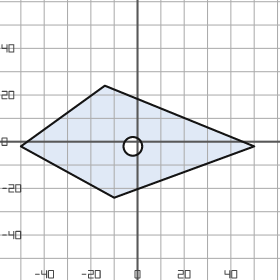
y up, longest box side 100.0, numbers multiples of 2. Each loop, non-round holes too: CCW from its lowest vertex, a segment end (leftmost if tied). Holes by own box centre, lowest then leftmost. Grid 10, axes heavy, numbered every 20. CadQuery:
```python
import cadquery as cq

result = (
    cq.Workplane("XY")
    .moveTo(-10.0, -24.0)
    .lineTo(50.0, -2.0)
    .lineTo(-14.0, 24.0)
    .lineTo(-50.0, -2.0)
    .close()
    .moveTo(-2.0, -2.0)
    .circle(4.0)
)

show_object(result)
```